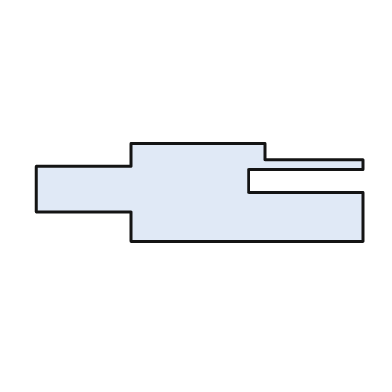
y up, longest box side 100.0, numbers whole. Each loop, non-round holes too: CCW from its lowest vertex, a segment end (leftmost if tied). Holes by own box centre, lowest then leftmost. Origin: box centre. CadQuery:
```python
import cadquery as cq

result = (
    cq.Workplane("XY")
    .moveTo(-21.0, -15.0)
    .lineTo(50.0, -15.0)
    .lineTo(50.0, 0.0)
    .lineTo(15.0, 0.0)
    .lineTo(15.0, 7.0)
    .lineTo(50.0, 7.0)
    .lineTo(50.0, 10.0)
    .lineTo(20.0, 10.0)
    .lineTo(20.0, 15.0)
    .lineTo(-21.0, 15.0)
    .lineTo(-21.0, 8.0)
    .lineTo(-50.0, 8.0)
    .lineTo(-50.0, -6.0)
    .lineTo(-21.0, -6.0)
    .close()
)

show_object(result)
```